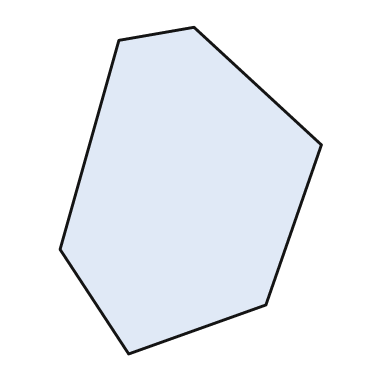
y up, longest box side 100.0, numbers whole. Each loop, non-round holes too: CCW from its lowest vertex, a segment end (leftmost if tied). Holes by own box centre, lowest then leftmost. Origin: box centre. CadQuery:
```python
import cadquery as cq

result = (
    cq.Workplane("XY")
    .moveTo(-19.0, -50.0)
    .lineTo(23.0, -35.0)
    .lineTo(40.0, 14.0)
    .lineTo(1.0, 50.0)
    .lineTo(-22.0, 46.0)
    .lineTo(-40.0, -18.0)
    .close()
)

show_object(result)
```